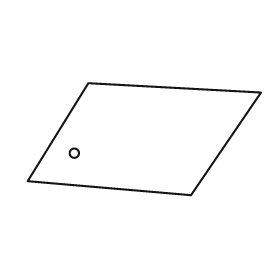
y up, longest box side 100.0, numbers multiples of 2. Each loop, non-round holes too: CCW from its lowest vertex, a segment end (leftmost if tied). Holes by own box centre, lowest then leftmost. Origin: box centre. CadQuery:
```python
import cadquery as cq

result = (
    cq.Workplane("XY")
    .moveTo(20.0, -24.0)
    .lineTo(50.0, 20.0)
    .lineTo(-24.0, 24.0)
    .lineTo(-50.0, -18.0)
    .close()
    .moveTo(-30.0, -6.0)
    .circle(2.0)
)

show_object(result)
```